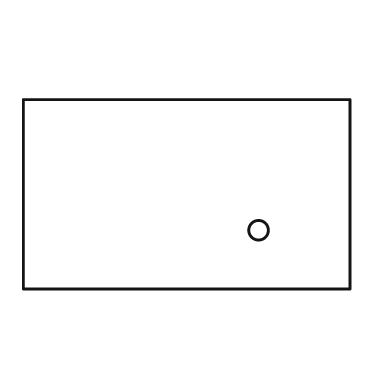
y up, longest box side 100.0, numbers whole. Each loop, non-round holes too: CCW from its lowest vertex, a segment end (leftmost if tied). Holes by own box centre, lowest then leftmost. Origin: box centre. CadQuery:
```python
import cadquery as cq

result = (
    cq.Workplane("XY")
    .moveTo(-50.0, -29.0)
    .lineTo(50.0, -29.0)
    .lineTo(50.0, 29.0)
    .lineTo(-50.0, 29.0)
    .close()
    .moveTo(22.0, -11.0)
    .circle(3.0)
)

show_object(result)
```